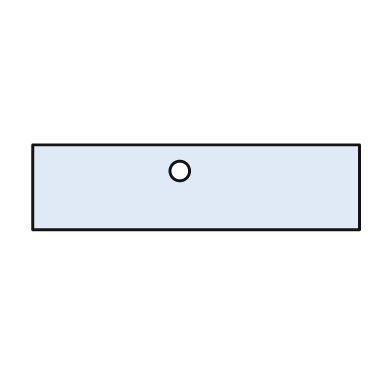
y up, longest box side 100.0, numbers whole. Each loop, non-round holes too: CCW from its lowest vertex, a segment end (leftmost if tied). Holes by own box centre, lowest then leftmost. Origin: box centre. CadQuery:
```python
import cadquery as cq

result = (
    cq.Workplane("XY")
    .moveTo(-50.0, -13.0)
    .lineTo(50.0, -13.0)
    .lineTo(50.0, 13.0)
    .lineTo(-50.0, 13.0)
    .close()
    .moveTo(-5.0, 5.0)
    .circle(3.0)
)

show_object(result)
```